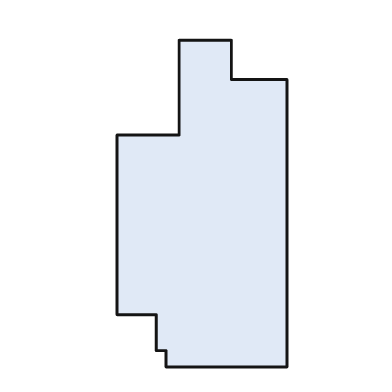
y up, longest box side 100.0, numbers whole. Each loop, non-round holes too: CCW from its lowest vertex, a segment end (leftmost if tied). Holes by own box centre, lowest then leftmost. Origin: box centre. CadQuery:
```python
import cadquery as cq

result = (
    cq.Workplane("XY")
    .moveTo(-11.0, -50.0)
    .lineTo(26.0, -50.0)
    .lineTo(26.0, 38.0)
    .lineTo(9.0, 38.0)
    .lineTo(9.0, 50.0)
    .lineTo(-7.0, 50.0)
    .lineTo(-7.0, 21.0)
    .lineTo(-26.0, 21.0)
    .lineTo(-26.0, -34.0)
    .lineTo(-14.0, -34.0)
    .lineTo(-14.0, -45.0)
    .lineTo(-11.0, -45.0)
    .close()
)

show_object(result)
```